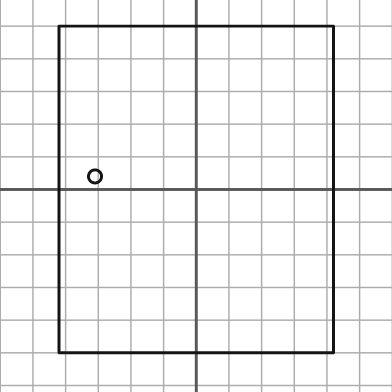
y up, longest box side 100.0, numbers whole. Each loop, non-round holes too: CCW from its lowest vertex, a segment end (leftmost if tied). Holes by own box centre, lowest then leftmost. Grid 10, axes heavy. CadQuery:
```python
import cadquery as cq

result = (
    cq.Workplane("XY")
    .moveTo(-42.0, -50.0)
    .lineTo(42.0, -50.0)
    .lineTo(42.0, 50.0)
    .lineTo(-42.0, 50.0)
    .close()
    .moveTo(-31.0, 4.0)
    .circle(2.0)
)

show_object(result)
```